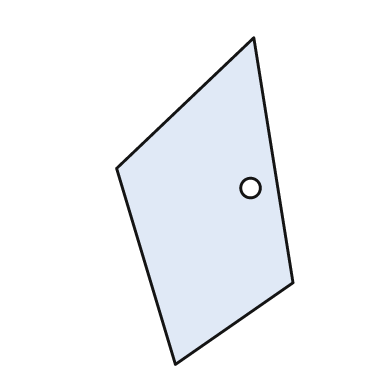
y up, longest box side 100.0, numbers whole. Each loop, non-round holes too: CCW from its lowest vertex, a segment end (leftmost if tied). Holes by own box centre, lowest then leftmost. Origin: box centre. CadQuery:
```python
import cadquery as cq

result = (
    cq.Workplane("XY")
    .moveTo(-9.0, -50.0)
    .lineTo(27.0, -25.0)
    .lineTo(15.0, 50.0)
    .lineTo(-27.0, 10.0)
    .close()
    .moveTo(14.0, 4.0)
    .circle(3.0)
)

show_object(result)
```